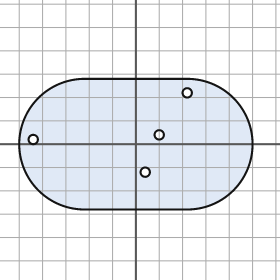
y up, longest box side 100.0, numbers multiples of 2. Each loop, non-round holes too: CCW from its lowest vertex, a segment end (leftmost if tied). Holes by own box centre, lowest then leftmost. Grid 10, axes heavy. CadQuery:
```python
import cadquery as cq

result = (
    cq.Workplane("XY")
    .moveTo(-22.0, -28.0)
    .lineTo(22.0, -28.0)
    .threePointArc((50.0, 0.0), (22.0, 28.0))
    .lineTo(-22.0, 28.0)
    .threePointArc((-50.0, 0.0), (-22.0, -28.0))
    .close()
    .moveTo(4.0, -12.0)
    .circle(2.0)
    .moveTo(-44.0, 2.0)
    .circle(2.0)
    .moveTo(10.0, 4.0)
    .circle(2.0)
    .moveTo(22.0, 22.0)
    .circle(2.0)
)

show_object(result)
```